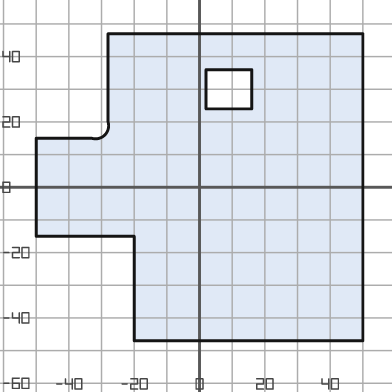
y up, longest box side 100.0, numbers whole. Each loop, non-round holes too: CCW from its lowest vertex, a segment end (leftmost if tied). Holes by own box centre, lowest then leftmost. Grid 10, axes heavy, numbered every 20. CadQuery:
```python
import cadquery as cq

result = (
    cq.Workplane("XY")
    .moveTo(-20.0, -47.0)
    .lineTo(50.0, -47.0)
    .lineTo(50.0, 47.0)
    .lineTo(-28.0, 47.0)
    .lineTo(-28.0, 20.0)
    .threePointArc((-29.0, 16.0), (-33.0, 15.0))
    .lineTo(-50.0, 15.0)
    .lineTo(-50.0, -15.0)
    .lineTo(-20.0, -15.0)
    .close()
    .moveTo(2.0, 24.0)
    .lineTo(16.0, 24.0)
    .lineTo(16.0, 36.0)
    .lineTo(2.0, 36.0)
    .close()
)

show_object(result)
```